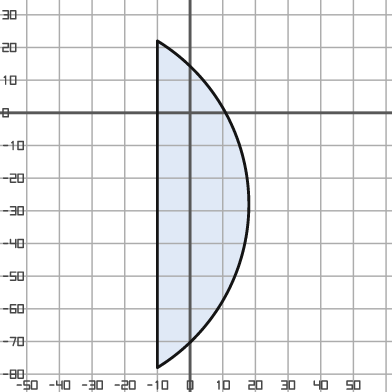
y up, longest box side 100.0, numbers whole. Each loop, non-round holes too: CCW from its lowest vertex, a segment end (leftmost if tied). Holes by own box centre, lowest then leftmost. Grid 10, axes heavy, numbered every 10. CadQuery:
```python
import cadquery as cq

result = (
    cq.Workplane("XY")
    .moveTo(-10.0, -78.0)
    .threePointArc((18.0, -28.0), (-10.0, 22.0))
    .close()
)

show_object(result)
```